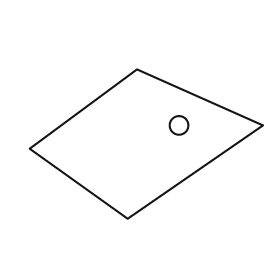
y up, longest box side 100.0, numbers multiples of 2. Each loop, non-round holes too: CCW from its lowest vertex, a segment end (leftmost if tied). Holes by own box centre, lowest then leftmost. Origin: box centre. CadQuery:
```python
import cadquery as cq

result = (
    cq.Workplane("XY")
    .moveTo(-8.0, -32.0)
    .lineTo(50.0, 8.0)
    .lineTo(-4.0, 32.0)
    .lineTo(-50.0, -2.0)
    .close()
    .moveTo(14.0, 8.0)
    .circle(4.0)
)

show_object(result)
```